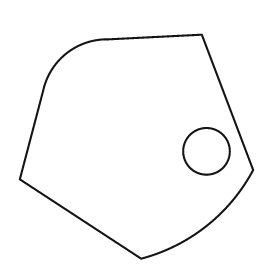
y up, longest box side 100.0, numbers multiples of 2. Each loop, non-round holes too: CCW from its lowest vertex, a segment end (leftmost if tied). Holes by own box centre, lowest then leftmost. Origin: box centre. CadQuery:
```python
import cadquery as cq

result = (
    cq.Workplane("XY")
    .moveTo(2.0, -48.0)
    .threePointArc((30.0, -34.0), (50.0, -10.0))
    .lineTo(28.0, 48.0)
    .lineTo(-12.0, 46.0)
    .threePointArc((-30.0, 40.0), (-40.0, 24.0))
    .lineTo(-50.0, -14.0)
    .close()
    .moveTo(30.0, -2.0)
    .circle(10.0)
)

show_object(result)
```